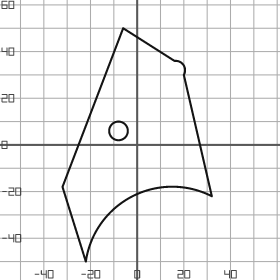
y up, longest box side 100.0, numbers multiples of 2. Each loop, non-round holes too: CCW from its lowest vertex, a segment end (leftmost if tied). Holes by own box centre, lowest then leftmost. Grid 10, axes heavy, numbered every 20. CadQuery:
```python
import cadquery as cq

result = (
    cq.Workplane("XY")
    .moveTo(-22.0, -50.0)
    .threePointArc((-2.0, -22.0), (32.0, -22.0))
    .lineTo(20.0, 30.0)
    .threePointArc((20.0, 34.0), (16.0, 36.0))
    .lineTo(-6.0, 50.0)
    .lineTo(-32.0, -18.0)
    .close()
    .moveTo(-8.0, 6.0)
    .circle(4.0)
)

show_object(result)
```